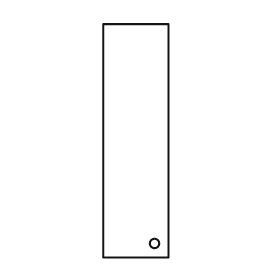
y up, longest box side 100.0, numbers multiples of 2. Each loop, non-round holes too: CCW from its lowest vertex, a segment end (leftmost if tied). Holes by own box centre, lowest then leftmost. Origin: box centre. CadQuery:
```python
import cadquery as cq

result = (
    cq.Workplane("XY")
    .moveTo(-14.0, -50.0)
    .lineTo(14.0, -50.0)
    .lineTo(14.0, 50.0)
    .lineTo(-14.0, 50.0)
    .close()
    .moveTo(8.0, -44.0)
    .circle(2.0)
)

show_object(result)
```